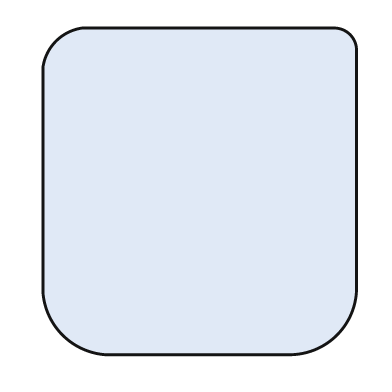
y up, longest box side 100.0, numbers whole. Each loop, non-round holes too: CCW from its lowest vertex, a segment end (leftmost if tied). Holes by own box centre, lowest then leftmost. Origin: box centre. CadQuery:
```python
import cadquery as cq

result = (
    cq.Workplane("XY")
    .moveTo(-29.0, -50.0)
    .lineTo(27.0, -50.0)
    .threePointArc((42.0, -44.0), (48.0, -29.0))
    .lineTo(48.0, 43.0)
    .threePointArc((46.0, 48.0), (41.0, 50.0))
    .lineTo(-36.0, 50.0)
    .threePointArc((-44.0, 46.0), (-48.0, 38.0))
    .lineTo(-48.0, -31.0)
    .threePointArc((-42.0, -44.0), (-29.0, -50.0))
    .close()
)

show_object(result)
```